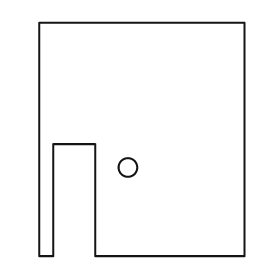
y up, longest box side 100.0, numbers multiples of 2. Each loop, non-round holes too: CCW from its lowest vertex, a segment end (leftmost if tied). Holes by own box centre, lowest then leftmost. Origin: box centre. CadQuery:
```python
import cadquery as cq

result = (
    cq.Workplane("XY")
    .moveTo(-44.0, -50.0)
    .lineTo(-38.0, -50.0)
    .lineTo(-38.0, -2.0)
    .lineTo(-20.0, -2.0)
    .lineTo(-20.0, -50.0)
    .lineTo(44.0, -50.0)
    .lineTo(44.0, 50.0)
    .lineTo(-44.0, 50.0)
    .close()
    .moveTo(-6.0, -12.0)
    .circle(4.0)
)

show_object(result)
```